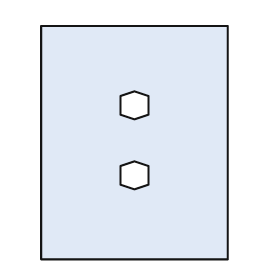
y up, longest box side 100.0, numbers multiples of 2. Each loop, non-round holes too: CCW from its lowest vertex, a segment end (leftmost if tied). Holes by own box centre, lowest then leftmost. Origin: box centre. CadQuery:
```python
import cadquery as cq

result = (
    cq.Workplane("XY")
    .moveTo(-40.0, -50.0)
    .lineTo(40.0, -50.0)
    .lineTo(40.0, 50.0)
    .lineTo(-40.0, 50.0)
    .close()
    .moveTo(0.0, -20.0)
    .lineTo(6.0, -18.0)
    .lineTo(6.0, -10.0)
    .lineTo(0.0, -8.0)
    .lineTo(-6.0, -10.0)
    .lineTo(-6.0, -18.0)
    .close()
    .moveTo(0.0, 10.0)
    .lineTo(6.0, 12.0)
    .lineTo(6.0, 20.0)
    .lineTo(0.0, 22.0)
    .lineTo(-6.0, 20.0)
    .lineTo(-6.0, 12.0)
    .close()
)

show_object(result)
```